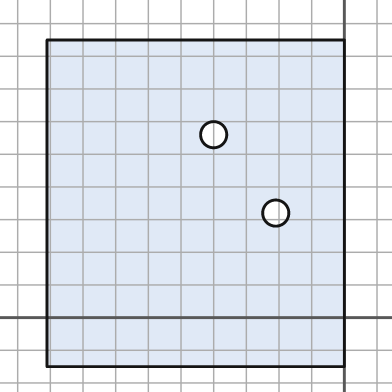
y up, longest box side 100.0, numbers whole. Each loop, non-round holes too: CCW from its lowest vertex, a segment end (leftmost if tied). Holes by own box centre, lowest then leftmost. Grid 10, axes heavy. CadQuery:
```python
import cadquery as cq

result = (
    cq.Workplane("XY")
    .moveTo(-91.0, -15.0)
    .lineTo(0.0, -15.0)
    .lineTo(0.0, 85.0)
    .lineTo(-91.0, 85.0)
    .close()
    .moveTo(-21.0, 32.0)
    .circle(4.0)
    .moveTo(-40.0, 56.0)
    .circle(4.0)
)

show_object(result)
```